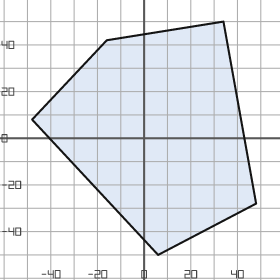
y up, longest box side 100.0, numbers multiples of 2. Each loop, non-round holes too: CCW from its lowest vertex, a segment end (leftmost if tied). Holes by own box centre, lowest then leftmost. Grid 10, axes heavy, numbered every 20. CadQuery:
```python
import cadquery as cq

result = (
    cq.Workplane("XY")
    .moveTo(6.0, -50.0)
    .lineTo(48.0, -28.0)
    .lineTo(34.0, 50.0)
    .lineTo(-16.0, 42.0)
    .lineTo(-48.0, 8.0)
    .close()
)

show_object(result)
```